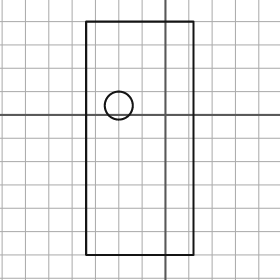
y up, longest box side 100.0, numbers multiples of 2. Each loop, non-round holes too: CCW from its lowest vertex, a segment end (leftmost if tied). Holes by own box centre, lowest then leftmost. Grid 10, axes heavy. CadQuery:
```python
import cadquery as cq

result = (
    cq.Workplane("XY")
    .moveTo(-34.0, -60.0)
    .lineTo(12.0, -60.0)
    .lineTo(12.0, 40.0)
    .lineTo(-34.0, 40.0)
    .close()
    .moveTo(-20.0, 4.0)
    .circle(6.0)
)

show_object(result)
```